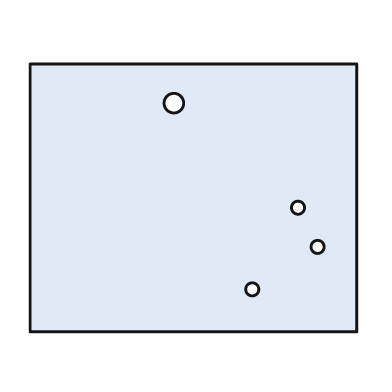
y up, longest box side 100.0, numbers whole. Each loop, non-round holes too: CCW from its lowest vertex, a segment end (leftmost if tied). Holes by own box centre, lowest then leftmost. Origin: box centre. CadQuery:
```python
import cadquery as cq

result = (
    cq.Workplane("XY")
    .moveTo(-50.0, -41.0)
    .lineTo(50.0, -41.0)
    .lineTo(50.0, 41.0)
    .lineTo(-50.0, 41.0)
    .close()
    .moveTo(18.0, -28.0)
    .circle(2.0)
    .moveTo(38.0, -15.0)
    .circle(2.0)
    .moveTo(32.0, -3.0)
    .circle(2.0)
    .moveTo(-6.0, 29.0)
    .circle(3.0)
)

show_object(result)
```